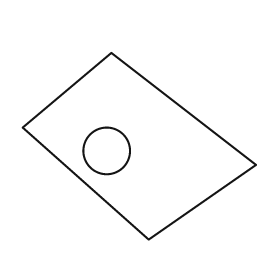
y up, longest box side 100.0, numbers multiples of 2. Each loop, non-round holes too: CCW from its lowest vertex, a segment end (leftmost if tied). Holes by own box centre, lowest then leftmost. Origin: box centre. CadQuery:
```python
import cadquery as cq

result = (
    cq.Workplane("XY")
    .moveTo(4.0, -40.0)
    .lineTo(50.0, -8.0)
    .lineTo(-12.0, 40.0)
    .lineTo(-50.0, 8.0)
    .close()
    .moveTo(-14.0, -2.0)
    .circle(10.0)
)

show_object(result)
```